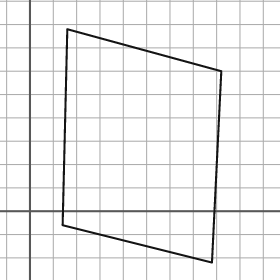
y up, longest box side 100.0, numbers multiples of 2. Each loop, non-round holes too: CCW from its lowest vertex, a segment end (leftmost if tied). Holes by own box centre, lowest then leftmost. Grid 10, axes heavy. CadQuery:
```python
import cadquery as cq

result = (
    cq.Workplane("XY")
    .moveTo(78.0, -22.0)
    .lineTo(82.0, 60.0)
    .lineTo(16.0, 78.0)
    .lineTo(14.0, -6.0)
    .close()
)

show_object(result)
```